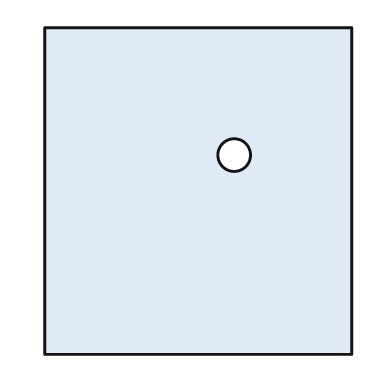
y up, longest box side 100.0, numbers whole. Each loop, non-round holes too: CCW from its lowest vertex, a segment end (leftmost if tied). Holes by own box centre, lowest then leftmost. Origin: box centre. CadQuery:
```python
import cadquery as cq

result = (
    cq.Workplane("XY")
    .moveTo(-47.0, -50.0)
    .lineTo(47.0, -50.0)
    .lineTo(47.0, 50.0)
    .lineTo(-47.0, 50.0)
    .close()
    .moveTo(11.0, 11.0)
    .circle(5.0)
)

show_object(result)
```